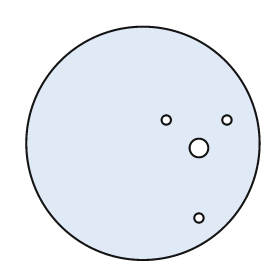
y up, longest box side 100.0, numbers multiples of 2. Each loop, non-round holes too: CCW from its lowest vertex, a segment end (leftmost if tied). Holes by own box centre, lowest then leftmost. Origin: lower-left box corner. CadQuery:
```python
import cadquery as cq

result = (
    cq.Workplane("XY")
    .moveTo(50.0, 50.0)
    .circle(50.0)
    .moveTo(74.0, 18.0)
    .circle(2.0)
    .moveTo(74.0, 48.0)
    .circle(4.0)
    .moveTo(60.0, 60.0)
    .circle(2.0)
    .moveTo(86.0, 60.0)
    .circle(2.0)
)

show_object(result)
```